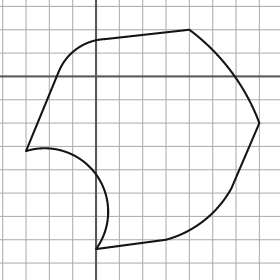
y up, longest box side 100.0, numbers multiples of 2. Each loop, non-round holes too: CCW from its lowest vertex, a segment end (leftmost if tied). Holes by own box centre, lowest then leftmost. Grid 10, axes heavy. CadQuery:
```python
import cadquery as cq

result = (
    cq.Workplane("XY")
    .moveTo(0.0, -74.0)
    .lineTo(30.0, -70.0)
    .threePointArc((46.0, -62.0), (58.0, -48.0))
    .lineTo(70.0, -20.0)
    .threePointArc((58.0, 2.0), (40.0, 20.0))
    .lineTo(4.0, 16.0)
    .threePointArc((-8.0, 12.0), (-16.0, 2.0))
    .lineTo(-30.0, -32.0)
    .threePointArc((0.0, -42.0), (0.0, -74.0))
    .close()
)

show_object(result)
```